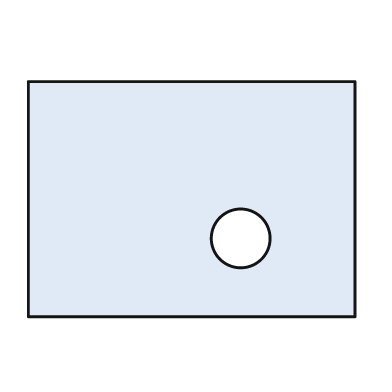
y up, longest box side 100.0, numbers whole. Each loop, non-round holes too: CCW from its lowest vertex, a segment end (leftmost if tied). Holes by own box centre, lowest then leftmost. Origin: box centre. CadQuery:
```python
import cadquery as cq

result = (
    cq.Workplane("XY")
    .moveTo(-50.0, -36.0)
    .lineTo(50.0, -36.0)
    .lineTo(50.0, 36.0)
    .lineTo(-50.0, 36.0)
    .close()
    .moveTo(15.0, -12.0)
    .circle(9.0)
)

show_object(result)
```